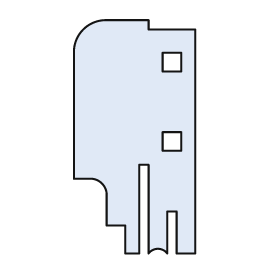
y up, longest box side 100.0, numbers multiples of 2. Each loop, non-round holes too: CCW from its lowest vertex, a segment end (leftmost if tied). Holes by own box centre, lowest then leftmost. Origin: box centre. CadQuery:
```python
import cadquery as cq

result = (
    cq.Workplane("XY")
    .moveTo(-4.0, -50.0)
    .lineTo(2.0, -50.0)
    .lineTo(2.0, -12.0)
    .lineTo(6.0, -12.0)
    .lineTo(6.0, -50.0)
    .threePointArc((10.0, -48.0), (14.0, -50.0))
    .lineTo(14.0, -32.0)
    .lineTo(18.0, -32.0)
    .lineTo(18.0, -50.0)
    .lineTo(26.0, -50.0)
    .lineTo(26.0, 46.0)
    .lineTo(6.0, 46.0)
    .lineTo(6.0, 50.0)
    .lineTo(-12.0, 50.0)
    .threePointArc((-22.0, 46.0), (-26.0, 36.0))
    .lineTo(-26.0, -18.0)
    .lineTo(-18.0, -18.0)
    .threePointArc((-14.0, -20.0), (-12.0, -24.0))
    .lineTo(-12.0, -38.0)
    .lineTo(-4.0, -38.0)
    .close()
    .moveTo(12.0, -6.0)
    .lineTo(20.0, -6.0)
    .lineTo(20.0, 2.0)
    .lineTo(12.0, 2.0)
    .close()
    .moveTo(12.0, 28.0)
    .lineTo(20.0, 28.0)
    .lineTo(20.0, 36.0)
    .lineTo(12.0, 36.0)
    .close()
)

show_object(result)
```